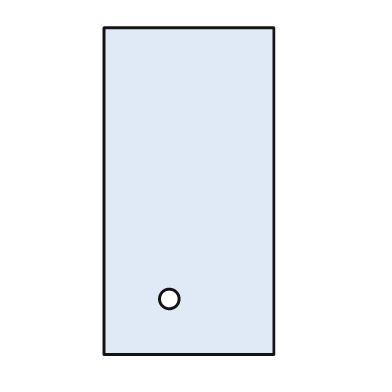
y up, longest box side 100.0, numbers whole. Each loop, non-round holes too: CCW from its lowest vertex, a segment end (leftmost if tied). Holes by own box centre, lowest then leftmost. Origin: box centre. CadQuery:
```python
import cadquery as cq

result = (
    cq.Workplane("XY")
    .moveTo(-26.0, -50.0)
    .lineTo(26.0, -50.0)
    .lineTo(26.0, 50.0)
    .lineTo(-26.0, 50.0)
    .close()
    .moveTo(-6.0, -33.0)
    .circle(3.0)
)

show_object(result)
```